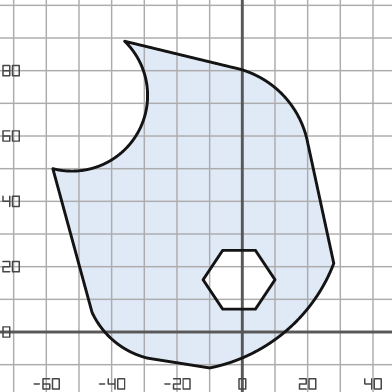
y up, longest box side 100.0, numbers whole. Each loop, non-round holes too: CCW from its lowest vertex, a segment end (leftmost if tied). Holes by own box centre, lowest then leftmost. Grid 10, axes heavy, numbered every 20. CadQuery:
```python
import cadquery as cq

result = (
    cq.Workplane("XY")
    .moveTo(-10.0, -11.0)
    .threePointArc((13.0, 0.0), (28.0, 21.0))
    .lineTo(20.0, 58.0)
    .threePointArc((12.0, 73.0), (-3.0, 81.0))
    .lineTo(-36.0, 89.0)
    .threePointArc((-32.0, 61.0), (-58.0, 50.0))
    .lineTo(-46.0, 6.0)
    .threePointArc((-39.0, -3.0), (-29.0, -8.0))
    .close()
    .moveTo(-6.0, 7.0)
    .lineTo(4.0, 7.0)
    .lineTo(10.0, 16.0)
    .lineTo(4.0, 25.0)
    .lineTo(-6.0, 25.0)
    .lineTo(-12.0, 16.0)
    .close()
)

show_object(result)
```